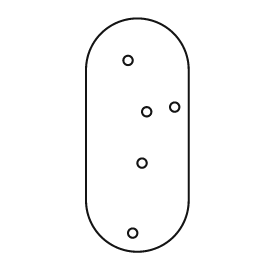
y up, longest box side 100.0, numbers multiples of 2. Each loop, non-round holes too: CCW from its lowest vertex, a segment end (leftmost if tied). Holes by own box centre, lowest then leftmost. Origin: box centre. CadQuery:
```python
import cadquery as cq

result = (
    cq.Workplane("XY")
    .moveTo(-22.0, -28.0)
    .threePointArc((0.0, -50.0), (22.0, -28.0))
    .lineTo(22.0, 28.0)
    .threePointArc((0.0, 50.0), (-22.0, 28.0))
    .close()
    .moveTo(-2.0, -42.0)
    .circle(2.0)
    .moveTo(2.0, -12.0)
    .circle(2.0)
    .moveTo(4.0, 10.0)
    .circle(2.0)
    .moveTo(16.0, 12.0)
    .circle(2.0)
    .moveTo(-4.0, 32.0)
    .circle(2.0)
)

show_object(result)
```